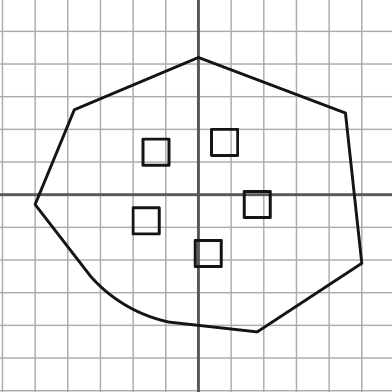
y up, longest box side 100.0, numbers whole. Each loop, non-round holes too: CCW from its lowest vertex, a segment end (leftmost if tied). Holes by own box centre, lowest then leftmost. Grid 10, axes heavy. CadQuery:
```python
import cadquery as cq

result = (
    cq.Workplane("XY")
    .moveTo(18.0, -42.0)
    .lineTo(50.0, -21.0)
    .lineTo(45.0, 25.0)
    .lineTo(0.0, 42.0)
    .lineTo(-38.0, 26.0)
    .lineTo(-50.0, -3.0)
    .lineTo(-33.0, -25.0)
    .threePointArc((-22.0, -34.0), (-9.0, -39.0))
    .close()
    .moveTo(-1.0, -22.0)
    .lineTo(7.0, -22.0)
    .lineTo(7.0, -14.0)
    .lineTo(-1.0, -14.0)
    .close()
    .moveTo(-20.0, -12.0)
    .lineTo(-12.0, -12.0)
    .lineTo(-12.0, -4.0)
    .lineTo(-20.0, -4.0)
    .close()
    .moveTo(14.0, -7.0)
    .lineTo(22.0, -7.0)
    .lineTo(22.0, 1.0)
    .lineTo(14.0, 1.0)
    .close()
    .moveTo(-17.0, 9.0)
    .lineTo(-9.0, 9.0)
    .lineTo(-9.0, 17.0)
    .lineTo(-17.0, 17.0)
    .close()
    .moveTo(4.0, 12.0)
    .lineTo(12.0, 12.0)
    .lineTo(12.0, 20.0)
    .lineTo(4.0, 20.0)
    .close()
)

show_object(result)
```